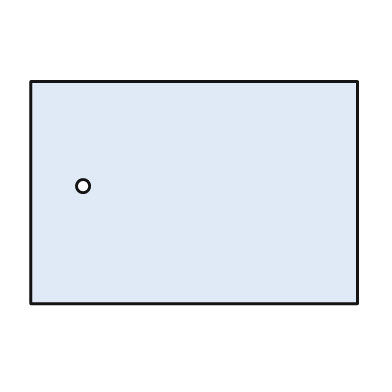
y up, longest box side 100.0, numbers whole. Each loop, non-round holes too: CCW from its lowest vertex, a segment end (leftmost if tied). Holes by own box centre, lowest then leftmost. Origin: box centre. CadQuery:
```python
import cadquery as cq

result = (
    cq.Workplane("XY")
    .moveTo(-50.0, -34.0)
    .lineTo(50.0, -34.0)
    .lineTo(50.0, 34.0)
    .lineTo(-50.0, 34.0)
    .close()
    .moveTo(-34.0, 2.0)
    .circle(2.0)
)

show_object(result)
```